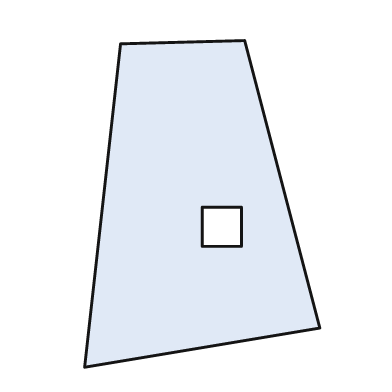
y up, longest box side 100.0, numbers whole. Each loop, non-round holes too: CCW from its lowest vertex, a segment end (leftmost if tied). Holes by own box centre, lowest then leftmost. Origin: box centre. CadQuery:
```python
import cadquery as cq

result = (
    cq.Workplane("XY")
    .moveTo(-36.0, -50.0)
    .lineTo(36.0, -38.0)
    .lineTo(13.0, 50.0)
    .lineTo(-25.0, 49.0)
    .close()
    .moveTo(0.0, -13.0)
    .lineTo(12.0, -13.0)
    .lineTo(12.0, -1.0)
    .lineTo(0.0, -1.0)
    .close()
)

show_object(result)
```